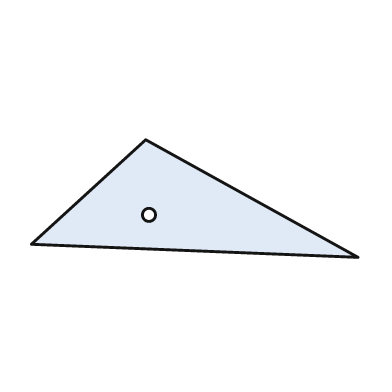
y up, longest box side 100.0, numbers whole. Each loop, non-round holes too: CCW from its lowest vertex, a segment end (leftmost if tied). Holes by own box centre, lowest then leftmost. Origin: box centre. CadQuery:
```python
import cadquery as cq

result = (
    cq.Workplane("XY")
    .moveTo(50.0, -18.0)
    .lineTo(-15.0, 18.0)
    .lineTo(-50.0, -14.0)
    .close()
    .moveTo(-14.0, -5.0)
    .circle(2.0)
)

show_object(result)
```